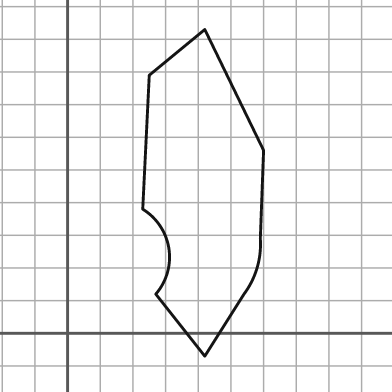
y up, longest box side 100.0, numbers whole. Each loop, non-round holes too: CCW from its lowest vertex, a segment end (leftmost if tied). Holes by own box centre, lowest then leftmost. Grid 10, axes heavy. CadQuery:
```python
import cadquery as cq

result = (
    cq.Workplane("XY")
    .moveTo(42.0, -7.0)
    .lineTo(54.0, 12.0)
    .threePointArc((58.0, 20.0), (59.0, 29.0))
    .lineTo(60.0, 56.0)
    .lineTo(42.0, 93.0)
    .lineTo(25.0, 79.0)
    .lineTo(23.0, 38.0)
    .threePointArc((31.0, 26.0), (27.0, 12.0))
    .close()
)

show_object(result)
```